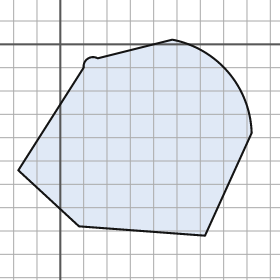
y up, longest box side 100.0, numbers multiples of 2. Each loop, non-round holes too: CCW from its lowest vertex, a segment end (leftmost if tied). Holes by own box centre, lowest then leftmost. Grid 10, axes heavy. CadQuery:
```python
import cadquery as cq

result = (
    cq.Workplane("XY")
    .moveTo(62.0, -82.0)
    .lineTo(82.0, -38.0)
    .threePointArc((72.0, -12.0), (48.0, 2.0))
    .lineTo(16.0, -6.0)
    .threePointArc((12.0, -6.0), (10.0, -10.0))
    .lineTo(-18.0, -54.0)
    .lineTo(8.0, -78.0)
    .close()
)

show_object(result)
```